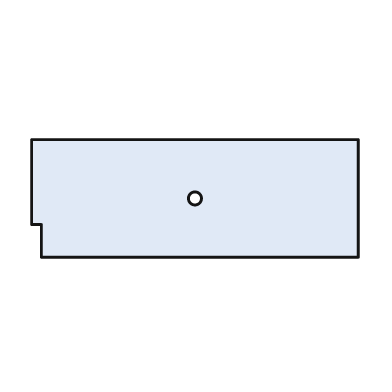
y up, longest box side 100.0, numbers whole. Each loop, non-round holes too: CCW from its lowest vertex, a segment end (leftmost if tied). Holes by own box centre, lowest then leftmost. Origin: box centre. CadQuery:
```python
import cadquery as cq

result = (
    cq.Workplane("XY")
    .moveTo(-47.0, -18.0)
    .lineTo(50.0, -18.0)
    .lineTo(50.0, 18.0)
    .lineTo(-50.0, 18.0)
    .lineTo(-50.0, -8.0)
    .lineTo(-47.0, -8.0)
    .close()
    .moveTo(0.0, 0.0)
    .circle(2.0)
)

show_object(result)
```